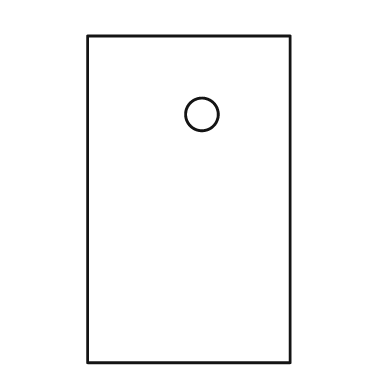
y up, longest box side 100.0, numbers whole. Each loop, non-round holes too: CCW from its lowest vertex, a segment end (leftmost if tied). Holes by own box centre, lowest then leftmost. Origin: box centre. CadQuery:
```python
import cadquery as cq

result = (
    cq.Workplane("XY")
    .moveTo(-31.0, -50.0)
    .lineTo(31.0, -50.0)
    .lineTo(31.0, 50.0)
    .lineTo(-31.0, 50.0)
    .close()
    .moveTo(4.0, 26.0)
    .circle(5.0)
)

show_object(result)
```